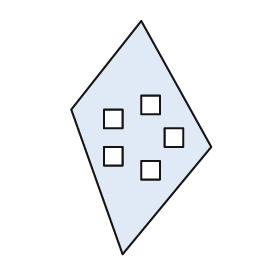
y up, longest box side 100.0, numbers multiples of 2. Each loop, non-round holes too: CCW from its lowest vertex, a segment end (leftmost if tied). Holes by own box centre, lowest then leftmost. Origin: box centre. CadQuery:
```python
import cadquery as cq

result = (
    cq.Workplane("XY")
    .moveTo(-8.0, -50.0)
    .lineTo(30.0, -4.0)
    .lineTo(0.0, 50.0)
    .lineTo(-30.0, 12.0)
    .close()
    .moveTo(0.0, -18.0)
    .lineTo(8.0, -18.0)
    .lineTo(8.0, -10.0)
    .lineTo(0.0, -10.0)
    .close()
    .moveTo(-16.0, -12.0)
    .lineTo(-8.0, -12.0)
    .lineTo(-8.0, -4.0)
    .lineTo(-16.0, -4.0)
    .close()
    .moveTo(10.0, -4.0)
    .lineTo(18.0, -4.0)
    .lineTo(18.0, 4.0)
    .lineTo(10.0, 4.0)
    .close()
    .moveTo(-16.0, 4.0)
    .lineTo(-8.0, 4.0)
    .lineTo(-8.0, 12.0)
    .lineTo(-16.0, 12.0)
    .close()
    .moveTo(0.0, 10.0)
    .lineTo(8.0, 10.0)
    .lineTo(8.0, 18.0)
    .lineTo(0.0, 18.0)
    .close()
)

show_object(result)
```